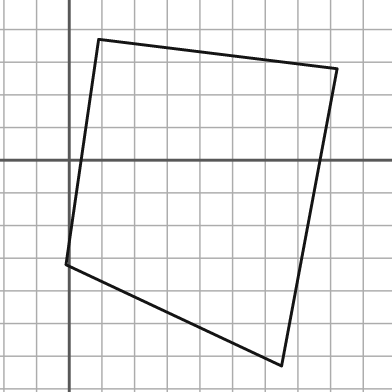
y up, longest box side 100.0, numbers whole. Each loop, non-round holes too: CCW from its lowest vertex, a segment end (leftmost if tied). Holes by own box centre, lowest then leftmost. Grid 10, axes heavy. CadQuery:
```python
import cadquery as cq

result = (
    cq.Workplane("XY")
    .moveTo(65.0, -63.0)
    .lineTo(82.0, 28.0)
    .lineTo(9.0, 37.0)
    .lineTo(-1.0, -32.0)
    .close()
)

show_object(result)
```